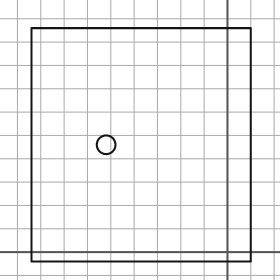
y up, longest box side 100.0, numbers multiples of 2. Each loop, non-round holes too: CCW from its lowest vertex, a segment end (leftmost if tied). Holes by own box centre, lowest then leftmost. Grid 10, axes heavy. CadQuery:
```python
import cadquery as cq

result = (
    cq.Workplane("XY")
    .moveTo(-84.0, -4.0)
    .lineTo(10.0, -4.0)
    .lineTo(10.0, 96.0)
    .lineTo(-84.0, 96.0)
    .close()
    .moveTo(-52.0, 46.0)
    .circle(4.0)
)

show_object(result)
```